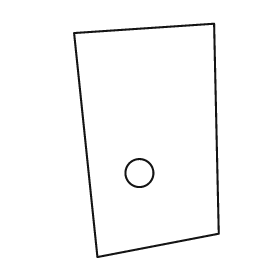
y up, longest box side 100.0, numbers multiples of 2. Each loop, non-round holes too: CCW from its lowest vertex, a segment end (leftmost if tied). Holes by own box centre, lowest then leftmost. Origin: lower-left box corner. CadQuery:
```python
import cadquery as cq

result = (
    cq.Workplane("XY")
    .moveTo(10.0, 0.0)
    .lineTo(62.0, 10.0)
    .lineTo(60.0, 100.0)
    .lineTo(0.0, 96.0)
    .close()
    .moveTo(28.0, 36.0)
    .circle(6.0)
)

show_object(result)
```